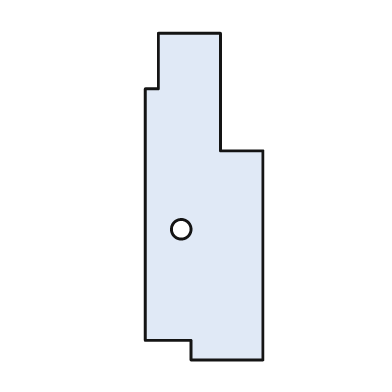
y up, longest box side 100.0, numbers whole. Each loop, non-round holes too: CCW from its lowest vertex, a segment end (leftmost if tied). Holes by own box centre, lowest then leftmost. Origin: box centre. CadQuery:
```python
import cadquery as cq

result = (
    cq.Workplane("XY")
    .moveTo(-4.0, -50.0)
    .lineTo(18.0, -50.0)
    .lineTo(18.0, 14.0)
    .lineTo(5.0, 14.0)
    .lineTo(5.0, 50.0)
    .lineTo(-14.0, 50.0)
    .lineTo(-14.0, 33.0)
    .lineTo(-18.0, 33.0)
    .lineTo(-18.0, -44.0)
    .lineTo(-4.0, -44.0)
    .close()
    .moveTo(-7.0, -10.0)
    .circle(3.0)
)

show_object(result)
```